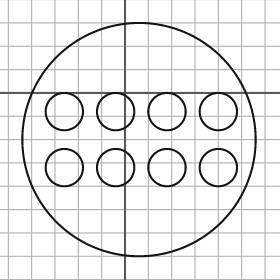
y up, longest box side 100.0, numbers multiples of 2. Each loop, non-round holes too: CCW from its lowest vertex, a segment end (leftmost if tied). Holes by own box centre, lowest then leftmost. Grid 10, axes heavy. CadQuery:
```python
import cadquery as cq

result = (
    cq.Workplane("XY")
    .moveTo(6.0, -20.0)
    .circle(50.0)
    .moveTo(-26.0, -32.0)
    .circle(8.0)
    .moveTo(-4.0, -32.0)
    .circle(8.0)
    .moveTo(18.0, -32.0)
    .circle(8.0)
    .moveTo(40.0, -32.0)
    .circle(8.0)
    .moveTo(-26.0, -8.0)
    .circle(8.0)
    .moveTo(-4.0, -8.0)
    .circle(8.0)
    .moveTo(18.0, -8.0)
    .circle(8.0)
    .moveTo(40.0, -8.0)
    .circle(8.0)
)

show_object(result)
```